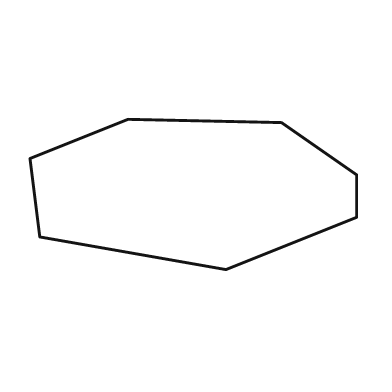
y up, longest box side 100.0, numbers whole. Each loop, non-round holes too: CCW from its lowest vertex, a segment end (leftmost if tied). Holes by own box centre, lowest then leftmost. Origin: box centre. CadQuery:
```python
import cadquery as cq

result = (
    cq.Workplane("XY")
    .moveTo(10.0, -23.0)
    .lineTo(50.0, -7.0)
    .lineTo(50.0, 6.0)
    .lineTo(27.0, 22.0)
    .lineTo(-20.0, 23.0)
    .lineTo(-50.0, 11.0)
    .lineTo(-47.0, -13.0)
    .close()
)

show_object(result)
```